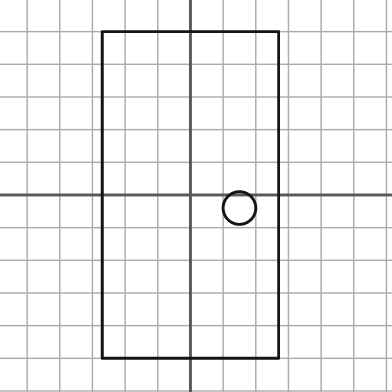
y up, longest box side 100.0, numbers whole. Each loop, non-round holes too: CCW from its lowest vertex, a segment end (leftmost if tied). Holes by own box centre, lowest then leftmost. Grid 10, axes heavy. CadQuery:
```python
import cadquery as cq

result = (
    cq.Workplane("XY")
    .moveTo(-27.0, -50.0)
    .lineTo(27.0, -50.0)
    .lineTo(27.0, 50.0)
    .lineTo(-27.0, 50.0)
    .close()
    .moveTo(15.0, -4.0)
    .circle(5.0)
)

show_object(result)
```